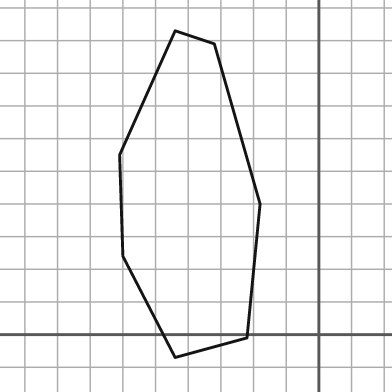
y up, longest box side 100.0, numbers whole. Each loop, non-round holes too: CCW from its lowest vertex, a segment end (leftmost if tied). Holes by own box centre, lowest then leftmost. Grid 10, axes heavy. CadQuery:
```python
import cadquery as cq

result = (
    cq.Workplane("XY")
    .moveTo(-44.0, -7.0)
    .lineTo(-22.0, -1.0)
    .lineTo(-18.0, 40.0)
    .lineTo(-32.0, 89.0)
    .lineTo(-44.0, 93.0)
    .lineTo(-61.0, 55.0)
    .lineTo(-60.0, 24.0)
    .close()
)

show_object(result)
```